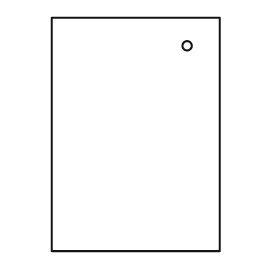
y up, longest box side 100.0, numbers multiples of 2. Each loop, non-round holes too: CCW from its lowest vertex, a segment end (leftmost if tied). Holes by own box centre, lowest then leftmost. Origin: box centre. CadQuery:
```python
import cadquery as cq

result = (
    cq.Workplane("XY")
    .moveTo(-36.0, -50.0)
    .lineTo(36.0, -50.0)
    .lineTo(36.0, 50.0)
    .lineTo(-36.0, 50.0)
    .close()
    .moveTo(22.0, 38.0)
    .circle(2.0)
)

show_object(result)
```